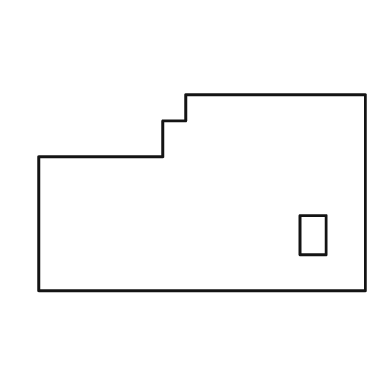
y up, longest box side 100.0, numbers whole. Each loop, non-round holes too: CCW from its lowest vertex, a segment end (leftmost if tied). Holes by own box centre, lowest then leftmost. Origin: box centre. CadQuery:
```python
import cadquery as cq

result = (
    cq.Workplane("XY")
    .moveTo(-50.0, -30.0)
    .lineTo(50.0, -30.0)
    .lineTo(50.0, 30.0)
    .lineTo(-5.0, 30.0)
    .lineTo(-5.0, 22.0)
    .lineTo(-12.0, 22.0)
    .lineTo(-12.0, 11.0)
    .lineTo(-50.0, 11.0)
    .close()
    .moveTo(30.0, -19.0)
    .lineTo(38.0, -19.0)
    .lineTo(38.0, -7.0)
    .lineTo(30.0, -7.0)
    .close()
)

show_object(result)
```